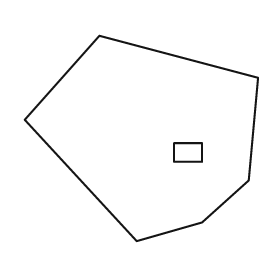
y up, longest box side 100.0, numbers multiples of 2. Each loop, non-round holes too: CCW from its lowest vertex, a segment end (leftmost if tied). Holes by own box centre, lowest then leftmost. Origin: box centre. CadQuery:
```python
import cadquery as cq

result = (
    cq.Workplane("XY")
    .moveTo(-2.0, -44.0)
    .lineTo(26.0, -36.0)
    .lineTo(46.0, -18.0)
    .lineTo(50.0, 26.0)
    .lineTo(-18.0, 44.0)
    .lineTo(-50.0, 8.0)
    .close()
    .moveTo(14.0, -10.0)
    .lineTo(26.0, -10.0)
    .lineTo(26.0, -2.0)
    .lineTo(14.0, -2.0)
    .close()
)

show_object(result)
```